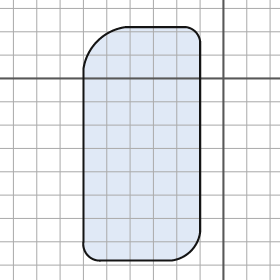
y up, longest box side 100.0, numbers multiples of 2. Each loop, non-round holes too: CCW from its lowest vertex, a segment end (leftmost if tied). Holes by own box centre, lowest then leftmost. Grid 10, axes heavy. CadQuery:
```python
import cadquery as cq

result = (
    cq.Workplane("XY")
    .moveTo(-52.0, -78.0)
    .lineTo(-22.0, -78.0)
    .threePointArc((-14.0, -74.0), (-10.0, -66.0))
    .lineTo(-10.0, 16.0)
    .threePointArc((-12.0, 20.0), (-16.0, 22.0))
    .lineTo(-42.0, 22.0)
    .threePointArc((-54.0, 16.0), (-60.0, 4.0))
    .lineTo(-60.0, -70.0)
    .threePointArc((-58.0, -76.0), (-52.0, -78.0))
    .close()
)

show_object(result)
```